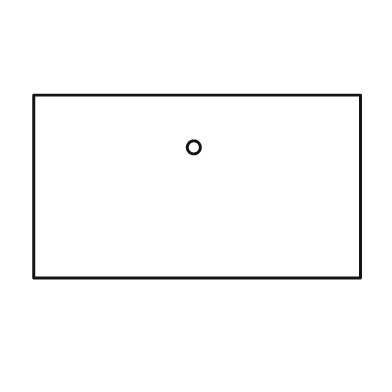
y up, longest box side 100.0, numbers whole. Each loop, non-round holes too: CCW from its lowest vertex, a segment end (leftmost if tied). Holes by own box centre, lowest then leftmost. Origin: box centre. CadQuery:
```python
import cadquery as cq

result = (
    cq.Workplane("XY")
    .moveTo(-50.0, -28.0)
    .lineTo(50.0, -28.0)
    .lineTo(50.0, 28.0)
    .lineTo(-50.0, 28.0)
    .close()
    .moveTo(-1.0, 12.0)
    .circle(2.0)
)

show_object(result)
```